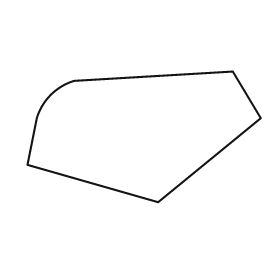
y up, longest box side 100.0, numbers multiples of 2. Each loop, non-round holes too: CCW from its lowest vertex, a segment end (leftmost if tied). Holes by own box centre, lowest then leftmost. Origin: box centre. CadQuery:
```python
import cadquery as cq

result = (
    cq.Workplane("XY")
    .moveTo(6.0, -28.0)
    .lineTo(50.0, 8.0)
    .lineTo(38.0, 28.0)
    .lineTo(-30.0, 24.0)
    .threePointArc((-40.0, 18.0), (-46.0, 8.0))
    .lineTo(-50.0, -12.0)
    .close()
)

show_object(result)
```